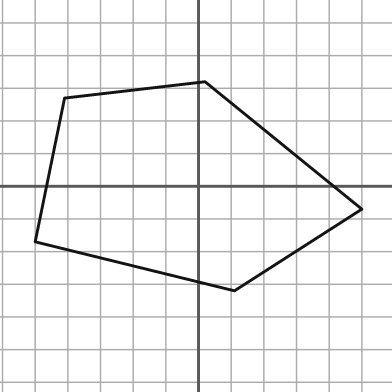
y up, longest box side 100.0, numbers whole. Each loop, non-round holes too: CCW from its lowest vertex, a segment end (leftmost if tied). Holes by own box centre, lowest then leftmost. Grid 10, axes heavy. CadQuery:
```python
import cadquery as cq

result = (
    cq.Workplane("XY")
    .moveTo(11.0, -32.0)
    .lineTo(50.0, -7.0)
    .lineTo(2.0, 32.0)
    .lineTo(-41.0, 27.0)
    .lineTo(-50.0, -17.0)
    .close()
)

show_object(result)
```